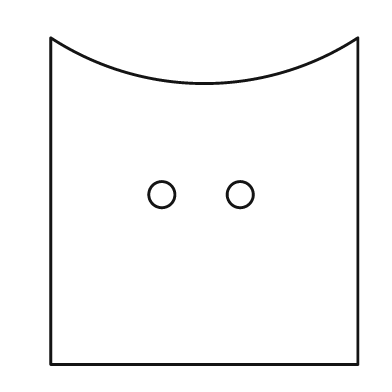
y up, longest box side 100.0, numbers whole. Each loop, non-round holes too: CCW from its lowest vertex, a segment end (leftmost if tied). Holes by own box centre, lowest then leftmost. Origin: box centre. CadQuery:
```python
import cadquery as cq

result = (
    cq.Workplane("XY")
    .moveTo(-47.0, -50.0)
    .lineTo(47.0, -50.0)
    .lineTo(47.0, 50.0)
    .threePointArc((0.0, 36.0), (-47.0, 50.0))
    .close()
    .moveTo(-13.0, 2.0)
    .circle(4.0)
    .moveTo(11.0, 2.0)
    .circle(4.0)
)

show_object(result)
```